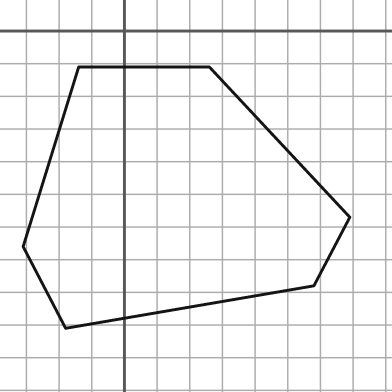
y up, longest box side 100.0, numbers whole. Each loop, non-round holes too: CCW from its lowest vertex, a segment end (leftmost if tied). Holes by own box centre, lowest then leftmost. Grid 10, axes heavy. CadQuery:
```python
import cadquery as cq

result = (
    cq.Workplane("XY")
    .moveTo(-18.0, -91.0)
    .lineTo(58.0, -78.0)
    .lineTo(69.0, -57.0)
    .lineTo(26.0, -11.0)
    .lineTo(-14.0, -11.0)
    .lineTo(-31.0, -66.0)
    .close()
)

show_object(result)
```